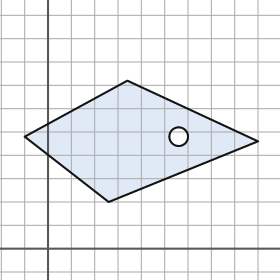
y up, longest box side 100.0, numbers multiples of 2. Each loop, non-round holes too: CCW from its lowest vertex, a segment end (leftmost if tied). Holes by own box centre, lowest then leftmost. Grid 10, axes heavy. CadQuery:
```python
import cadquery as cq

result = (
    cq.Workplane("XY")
    .moveTo(26.0, 20.0)
    .lineTo(90.0, 46.0)
    .lineTo(34.0, 72.0)
    .lineTo(-10.0, 48.0)
    .close()
    .moveTo(56.0, 48.0)
    .circle(4.0)
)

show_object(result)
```